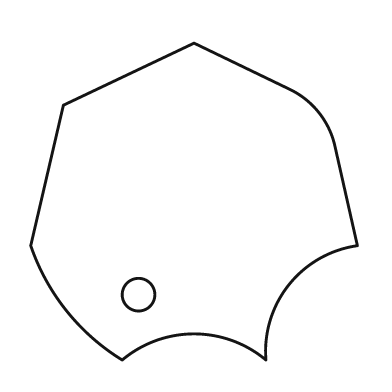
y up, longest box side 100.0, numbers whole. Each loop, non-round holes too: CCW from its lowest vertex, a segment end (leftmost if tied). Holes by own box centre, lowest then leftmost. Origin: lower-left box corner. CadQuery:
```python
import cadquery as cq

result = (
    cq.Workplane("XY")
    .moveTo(28.0, 0.0)
    .threePointArc((50.0, 8.0), (72.0, 0.0))
    .threePointArc((79.0, 23.0), (100.0, 35.0))
    .lineTo(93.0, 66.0)
    .threePointArc((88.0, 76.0), (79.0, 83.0))
    .lineTo(50.0, 97.0)
    .lineTo(10.0, 78.0)
    .lineTo(0.0, 35.0)
    .threePointArc((11.0, 15.0), (28.0, 0.0))
    .close()
    .moveTo(33.0, 20.0)
    .circle(5.0)
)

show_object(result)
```